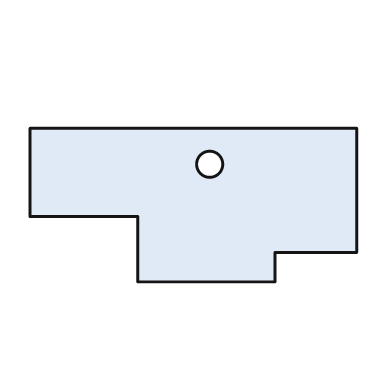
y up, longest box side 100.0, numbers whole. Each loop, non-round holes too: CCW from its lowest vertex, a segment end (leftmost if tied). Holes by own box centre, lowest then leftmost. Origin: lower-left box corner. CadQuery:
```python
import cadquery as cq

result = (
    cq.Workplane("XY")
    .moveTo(33.0, 0.0)
    .lineTo(75.0, 0.0)
    .lineTo(75.0, 9.0)
    .lineTo(100.0, 9.0)
    .lineTo(100.0, 47.0)
    .lineTo(0.0, 47.0)
    .lineTo(0.0, 20.0)
    .lineTo(33.0, 20.0)
    .close()
    .moveTo(55.0, 36.0)
    .circle(4.0)
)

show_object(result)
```